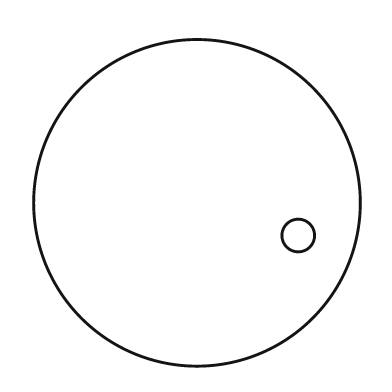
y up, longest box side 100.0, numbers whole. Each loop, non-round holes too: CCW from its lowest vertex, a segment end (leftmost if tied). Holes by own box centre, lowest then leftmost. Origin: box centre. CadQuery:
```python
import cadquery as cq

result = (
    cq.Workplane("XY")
    .moveTo(0.0, 0.0)
    .circle(50.0)
    .moveTo(31.0, -10.0)
    .circle(5.0)
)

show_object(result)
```